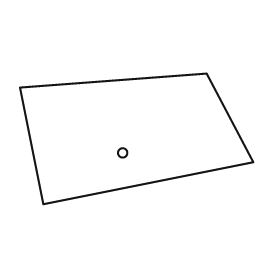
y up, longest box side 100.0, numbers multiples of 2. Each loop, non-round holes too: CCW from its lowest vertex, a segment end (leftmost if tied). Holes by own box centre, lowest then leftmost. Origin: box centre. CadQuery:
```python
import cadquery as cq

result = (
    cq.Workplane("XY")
    .moveTo(-40.0, -28.0)
    .lineTo(50.0, -10.0)
    .lineTo(30.0, 28.0)
    .lineTo(-50.0, 22.0)
    .close()
    .moveTo(-6.0, -6.0)
    .circle(2.0)
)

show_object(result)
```